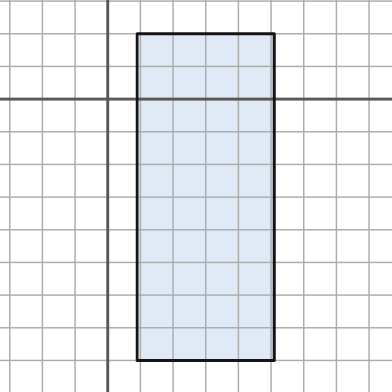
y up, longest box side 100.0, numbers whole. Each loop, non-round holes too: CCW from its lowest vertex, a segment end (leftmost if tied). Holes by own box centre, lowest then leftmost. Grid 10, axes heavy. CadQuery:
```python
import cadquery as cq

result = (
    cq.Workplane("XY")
    .moveTo(9.0, -80.0)
    .lineTo(51.0, -80.0)
    .lineTo(51.0, 20.0)
    .lineTo(9.0, 20.0)
    .close()
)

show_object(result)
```